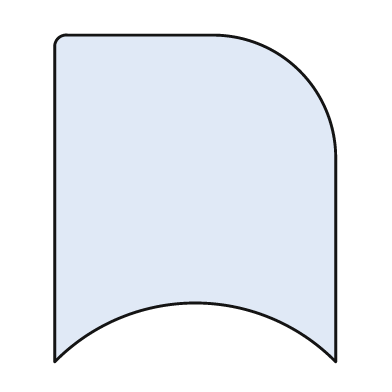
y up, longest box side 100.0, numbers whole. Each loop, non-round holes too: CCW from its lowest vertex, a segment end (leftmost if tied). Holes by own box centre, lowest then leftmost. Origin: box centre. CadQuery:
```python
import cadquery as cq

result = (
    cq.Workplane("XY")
    .moveTo(-43.0, -50.0)
    .threePointArc((0.0, -32.0), (43.0, -50.0))
    .lineTo(43.0, 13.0)
    .threePointArc((32.0, 39.0), (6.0, 50.0))
    .lineTo(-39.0, 50.0)
    .threePointArc((-42.0, 49.0), (-43.0, 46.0))
    .close()
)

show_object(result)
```